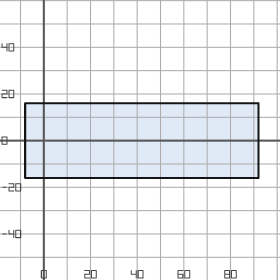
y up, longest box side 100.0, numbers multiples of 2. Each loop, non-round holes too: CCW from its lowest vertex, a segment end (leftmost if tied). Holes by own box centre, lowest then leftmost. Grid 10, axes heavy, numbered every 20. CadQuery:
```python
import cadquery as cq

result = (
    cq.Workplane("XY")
    .moveTo(-8.0, -16.0)
    .lineTo(92.0, -16.0)
    .lineTo(92.0, 16.0)
    .lineTo(-8.0, 16.0)
    .close()
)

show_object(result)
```